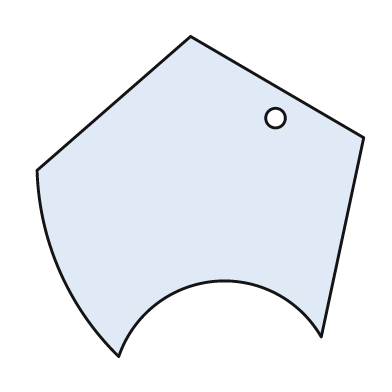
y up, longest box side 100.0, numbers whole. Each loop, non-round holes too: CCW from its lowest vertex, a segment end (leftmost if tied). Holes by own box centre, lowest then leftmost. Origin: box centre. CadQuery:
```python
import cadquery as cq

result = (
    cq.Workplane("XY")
    .moveTo(-25.0, -49.0)
    .threePointArc((4.0, -26.0), (37.0, -43.0))
    .lineTo(50.0, 18.0)
    .lineTo(-3.0, 49.0)
    .lineTo(-50.0, 8.0)
    .threePointArc((-43.0, -23.0), (-25.0, -49.0))
    .close()
    .moveTo(23.0, 24.0)
    .circle(3.0)
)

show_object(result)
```